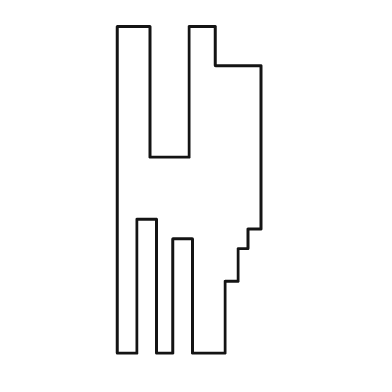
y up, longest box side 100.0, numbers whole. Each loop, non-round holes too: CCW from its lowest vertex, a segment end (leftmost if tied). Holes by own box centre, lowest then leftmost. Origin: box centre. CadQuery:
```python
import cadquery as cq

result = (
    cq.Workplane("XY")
    .moveTo(-22.0, -50.0)
    .lineTo(-16.0, -50.0)
    .lineTo(-16.0, -9.0)
    .lineTo(-10.0, -9.0)
    .lineTo(-10.0, -50.0)
    .lineTo(-5.0, -50.0)
    .lineTo(-5.0, -15.0)
    .lineTo(1.0, -15.0)
    .lineTo(1.0, -50.0)
    .lineTo(11.0, -50.0)
    .lineTo(11.0, -28.0)
    .lineTo(15.0, -28.0)
    .lineTo(15.0, -18.0)
    .lineTo(18.0, -18.0)
    .lineTo(18.0, -12.0)
    .lineTo(22.0, -12.0)
    .lineTo(22.0, 38.0)
    .lineTo(8.0, 38.0)
    .lineTo(8.0, 50.0)
    .lineTo(0.0, 50.0)
    .lineTo(0.0, 10.0)
    .lineTo(-12.0, 10.0)
    .lineTo(-12.0, 50.0)
    .lineTo(-22.0, 50.0)
    .close()
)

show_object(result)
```